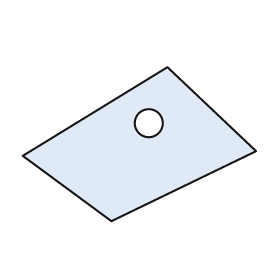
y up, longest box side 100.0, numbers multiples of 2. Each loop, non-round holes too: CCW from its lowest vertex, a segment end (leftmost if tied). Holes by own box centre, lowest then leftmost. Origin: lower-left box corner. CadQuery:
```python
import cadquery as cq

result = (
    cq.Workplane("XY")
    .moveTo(38.0, 0.0)
    .lineTo(100.0, 30.0)
    .lineTo(62.0, 66.0)
    .lineTo(0.0, 28.0)
    .close()
    .moveTo(54.0, 42.0)
    .circle(6.0)
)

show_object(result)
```